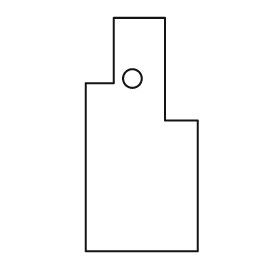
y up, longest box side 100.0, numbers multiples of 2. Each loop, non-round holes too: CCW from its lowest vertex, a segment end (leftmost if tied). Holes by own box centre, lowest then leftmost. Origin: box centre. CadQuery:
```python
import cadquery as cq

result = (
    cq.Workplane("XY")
    .moveTo(-24.0, -50.0)
    .lineTo(24.0, -50.0)
    .lineTo(24.0, 6.0)
    .lineTo(10.0, 6.0)
    .lineTo(10.0, 50.0)
    .lineTo(-12.0, 50.0)
    .lineTo(-12.0, 22.0)
    .lineTo(-24.0, 22.0)
    .close()
    .moveTo(-4.0, 24.0)
    .circle(4.0)
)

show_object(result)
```